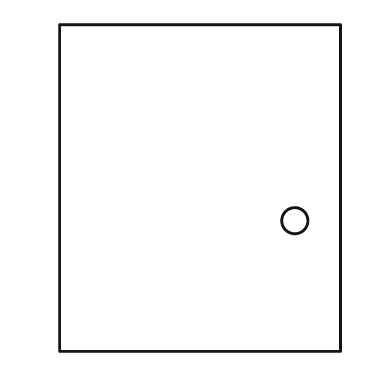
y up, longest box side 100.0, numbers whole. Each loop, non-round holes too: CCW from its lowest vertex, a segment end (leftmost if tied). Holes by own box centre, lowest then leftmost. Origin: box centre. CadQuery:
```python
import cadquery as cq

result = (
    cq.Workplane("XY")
    .moveTo(-43.0, -50.0)
    .lineTo(43.0, -50.0)
    .lineTo(43.0, 50.0)
    .lineTo(-43.0, 50.0)
    .close()
    .moveTo(29.0, -10.0)
    .circle(4.0)
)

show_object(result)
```